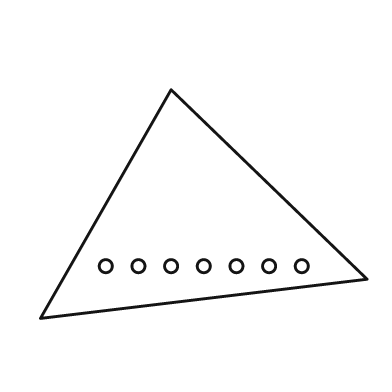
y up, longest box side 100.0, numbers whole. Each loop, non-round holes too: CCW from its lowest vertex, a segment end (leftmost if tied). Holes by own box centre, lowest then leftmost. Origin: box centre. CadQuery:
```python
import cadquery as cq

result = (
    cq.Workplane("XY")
    .moveTo(-50.0, -35.0)
    .lineTo(50.0, -23.0)
    .lineTo(-10.0, 35.0)
    .close()
    .moveTo(-30.0, -19.0)
    .circle(2.0)
    .moveTo(-20.0, -19.0)
    .circle(2.0)
    .moveTo(-10.0, -19.0)
    .circle(2.0)
    .moveTo(0.0, -19.0)
    .circle(2.0)
    .moveTo(10.0, -19.0)
    .circle(2.0)
    .moveTo(20.0, -19.0)
    .circle(2.0)
    .moveTo(30.0, -19.0)
    .circle(2.0)
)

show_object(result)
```